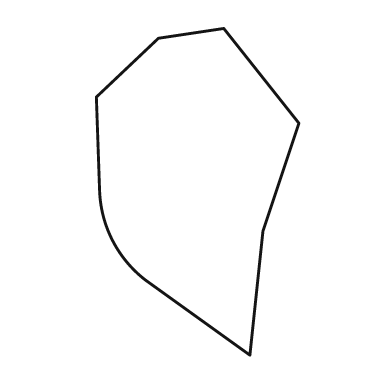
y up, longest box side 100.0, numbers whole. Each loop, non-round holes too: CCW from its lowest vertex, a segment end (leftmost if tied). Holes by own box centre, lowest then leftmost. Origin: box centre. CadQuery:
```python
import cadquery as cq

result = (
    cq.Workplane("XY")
    .moveTo(16.0, -50.0)
    .lineTo(20.0, -12.0)
    .lineTo(31.0, 21.0)
    .lineTo(8.0, 50.0)
    .lineTo(-12.0, 47.0)
    .lineTo(-31.0, 29.0)
    .lineTo(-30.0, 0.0)
    .threePointArc((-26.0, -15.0), (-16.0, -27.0))
    .close()
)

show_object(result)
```